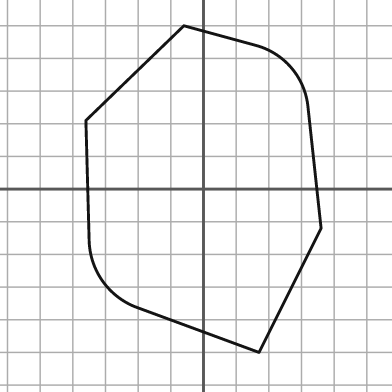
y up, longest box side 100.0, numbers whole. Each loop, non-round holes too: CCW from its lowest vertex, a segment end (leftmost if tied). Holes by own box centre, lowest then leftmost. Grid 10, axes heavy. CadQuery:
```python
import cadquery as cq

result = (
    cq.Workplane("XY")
    .moveTo(17.0, -50.0)
    .lineTo(36.0, -12.0)
    .lineTo(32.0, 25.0)
    .threePointArc((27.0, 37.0), (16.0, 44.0))
    .lineTo(-6.0, 50.0)
    .lineTo(-36.0, 21.0)
    .lineTo(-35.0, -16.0)
    .threePointArc((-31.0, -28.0), (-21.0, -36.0))
    .close()
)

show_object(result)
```